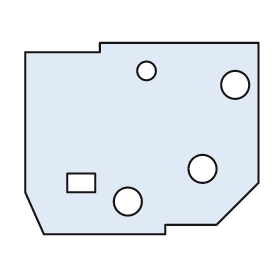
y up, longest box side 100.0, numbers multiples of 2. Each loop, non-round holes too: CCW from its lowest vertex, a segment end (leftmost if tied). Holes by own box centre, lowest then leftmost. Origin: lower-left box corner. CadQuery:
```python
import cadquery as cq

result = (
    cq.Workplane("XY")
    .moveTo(8.0, 0.0)
    .lineTo(60.0, 0.0)
    .lineTo(60.0, 4.0)
    .lineTo(82.0, 4.0)
    .lineTo(100.0, 22.0)
    .lineTo(100.0, 82.0)
    .lineTo(32.0, 82.0)
    .lineTo(32.0, 78.0)
    .lineTo(0.0, 78.0)
    .lineTo(0.0, 18.0)
    .close()
    .moveTo(44.0, 14.0)
    .circle(6.0)
    .moveTo(18.0, 18.0)
    .lineTo(30.0, 18.0)
    .lineTo(30.0, 26.0)
    .lineTo(18.0, 26.0)
    .close()
    .moveTo(76.0, 28.0)
    .circle(6.0)
    .moveTo(90.0, 64.0)
    .circle(6.0)
    .moveTo(52.0, 70.0)
    .circle(4.0)
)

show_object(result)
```